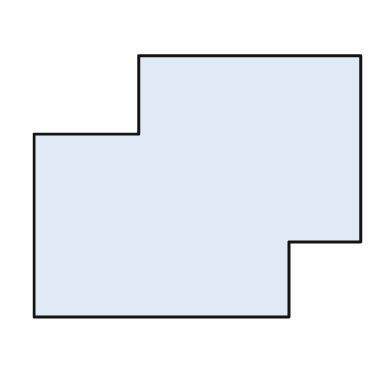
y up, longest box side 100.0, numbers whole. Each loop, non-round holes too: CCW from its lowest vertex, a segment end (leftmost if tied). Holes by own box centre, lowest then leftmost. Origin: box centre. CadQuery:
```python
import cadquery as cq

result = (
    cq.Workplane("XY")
    .moveTo(-50.0, -40.0)
    .lineTo(28.0, -40.0)
    .lineTo(28.0, -17.0)
    .lineTo(50.0, -17.0)
    .lineTo(50.0, 40.0)
    .lineTo(-18.0, 40.0)
    .lineTo(-18.0, 16.0)
    .lineTo(-50.0, 16.0)
    .close()
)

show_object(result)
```